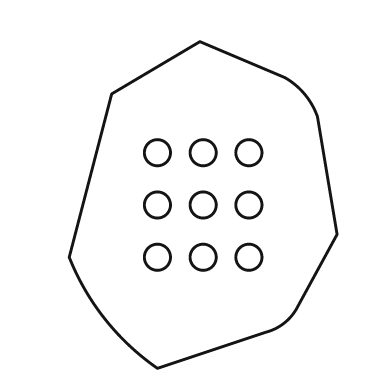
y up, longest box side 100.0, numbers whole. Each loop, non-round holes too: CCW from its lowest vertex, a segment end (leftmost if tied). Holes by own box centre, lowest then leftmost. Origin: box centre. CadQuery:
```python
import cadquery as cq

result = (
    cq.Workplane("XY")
    .moveTo(-14.0, -50.0)
    .lineTo(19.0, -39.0)
    .threePointArc((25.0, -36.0), (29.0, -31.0))
    .lineTo(41.0, -9.0)
    .lineTo(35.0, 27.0)
    .threePointArc((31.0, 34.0), (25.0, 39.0))
    .lineTo(-1.0, 50.0)
    .lineTo(-28.0, 34.0)
    .lineTo(-41.0, -16.0)
    .threePointArc((-30.0, -35.0), (-14.0, -50.0))
    .close()
    .moveTo(-14.0, -16.0)
    .circle(4.0)
    .moveTo(0.0, -16.0)
    .circle(4.0)
    .moveTo(14.0, -16.0)
    .circle(4.0)
    .moveTo(-14.0, 0.0)
    .circle(4.0)
    .moveTo(0.0, 0.0)
    .circle(4.0)
    .moveTo(14.0, 0.0)
    .circle(4.0)
    .moveTo(-14.0, 16.0)
    .circle(4.0)
    .moveTo(0.0, 16.0)
    .circle(4.0)
    .moveTo(14.0, 16.0)
    .circle(4.0)
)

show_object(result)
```